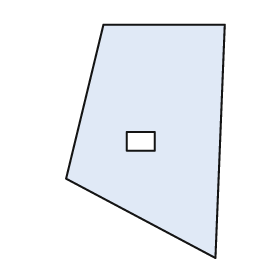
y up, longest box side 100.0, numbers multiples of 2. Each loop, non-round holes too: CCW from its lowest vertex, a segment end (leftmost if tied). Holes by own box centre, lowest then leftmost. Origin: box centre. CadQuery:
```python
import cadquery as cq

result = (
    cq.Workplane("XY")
    .moveTo(30.0, -50.0)
    .lineTo(34.0, 50.0)
    .lineTo(-18.0, 50.0)
    .lineTo(-34.0, -16.0)
    .close()
    .moveTo(-8.0, -4.0)
    .lineTo(4.0, -4.0)
    .lineTo(4.0, 4.0)
    .lineTo(-8.0, 4.0)
    .close()
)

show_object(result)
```